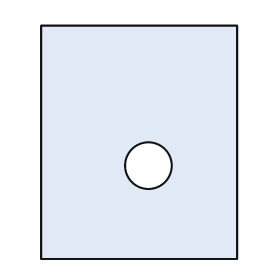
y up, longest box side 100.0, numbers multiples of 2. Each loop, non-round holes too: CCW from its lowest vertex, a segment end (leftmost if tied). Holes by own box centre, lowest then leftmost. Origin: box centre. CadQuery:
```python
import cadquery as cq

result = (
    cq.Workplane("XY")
    .moveTo(-42.0, -50.0)
    .lineTo(42.0, -50.0)
    .lineTo(42.0, 50.0)
    .lineTo(-42.0, 50.0)
    .close()
    .moveTo(4.0, -10.0)
    .circle(10.0)
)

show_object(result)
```